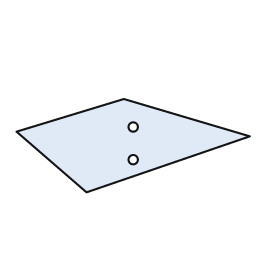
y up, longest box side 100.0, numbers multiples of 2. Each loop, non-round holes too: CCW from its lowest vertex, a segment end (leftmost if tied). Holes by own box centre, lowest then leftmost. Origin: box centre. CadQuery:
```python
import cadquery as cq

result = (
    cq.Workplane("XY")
    .moveTo(-20.0, -20.0)
    .lineTo(50.0, 4.0)
    .lineTo(-4.0, 20.0)
    .lineTo(-50.0, 6.0)
    .close()
    .moveTo(0.0, -6.0)
    .circle(2.0)
    .moveTo(0.0, 8.0)
    .circle(2.0)
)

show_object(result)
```